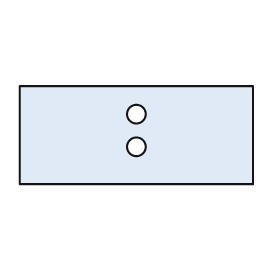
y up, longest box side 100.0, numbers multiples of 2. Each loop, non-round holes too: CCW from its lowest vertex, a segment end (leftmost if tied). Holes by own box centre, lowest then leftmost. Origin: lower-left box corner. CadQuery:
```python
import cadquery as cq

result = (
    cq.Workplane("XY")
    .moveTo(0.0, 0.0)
    .lineTo(100.0, 0.0)
    .lineTo(100.0, 42.0)
    .lineTo(0.0, 42.0)
    .close()
    .moveTo(50.0, 16.0)
    .circle(4.0)
    .moveTo(50.0, 30.0)
    .circle(4.0)
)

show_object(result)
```